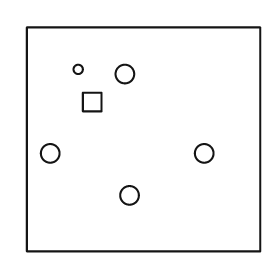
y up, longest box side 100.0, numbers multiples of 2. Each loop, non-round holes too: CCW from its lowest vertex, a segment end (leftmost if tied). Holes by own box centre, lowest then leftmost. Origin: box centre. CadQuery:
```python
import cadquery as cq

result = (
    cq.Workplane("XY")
    .moveTo(-50.0, -48.0)
    .lineTo(50.0, -48.0)
    .lineTo(50.0, 48.0)
    .lineTo(-50.0, 48.0)
    .close()
    .moveTo(-6.0, -24.0)
    .circle(4.0)
    .moveTo(-40.0, -6.0)
    .circle(4.0)
    .moveTo(26.0, -6.0)
    .circle(4.0)
    .moveTo(-26.0, 12.0)
    .lineTo(-18.0, 12.0)
    .lineTo(-18.0, 20.0)
    .lineTo(-26.0, 20.0)
    .close()
    .moveTo(-8.0, 28.0)
    .circle(4.0)
    .moveTo(-28.0, 30.0)
    .circle(2.0)
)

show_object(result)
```